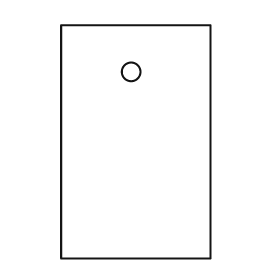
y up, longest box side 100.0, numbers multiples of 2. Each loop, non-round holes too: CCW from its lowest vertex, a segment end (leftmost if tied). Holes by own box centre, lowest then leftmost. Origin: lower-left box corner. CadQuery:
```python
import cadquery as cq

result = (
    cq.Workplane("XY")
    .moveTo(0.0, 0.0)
    .lineTo(64.0, 0.0)
    .lineTo(64.0, 100.0)
    .lineTo(0.0, 100.0)
    .close()
    .moveTo(30.0, 80.0)
    .circle(4.0)
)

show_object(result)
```